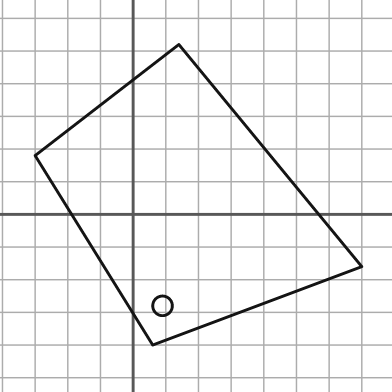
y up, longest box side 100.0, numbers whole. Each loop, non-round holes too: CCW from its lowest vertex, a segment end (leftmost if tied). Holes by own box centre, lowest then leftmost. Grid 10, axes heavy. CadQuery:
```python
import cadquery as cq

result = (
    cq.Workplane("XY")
    .moveTo(6.0, -40.0)
    .lineTo(70.0, -16.0)
    .lineTo(14.0, 52.0)
    .lineTo(-30.0, 18.0)
    .close()
    .moveTo(9.0, -28.0)
    .circle(3.0)
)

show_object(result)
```